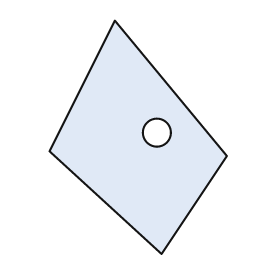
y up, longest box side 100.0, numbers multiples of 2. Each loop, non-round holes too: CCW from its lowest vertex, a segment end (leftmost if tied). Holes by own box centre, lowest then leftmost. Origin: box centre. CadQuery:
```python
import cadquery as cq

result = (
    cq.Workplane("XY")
    .moveTo(10.0, -50.0)
    .lineTo(38.0, -8.0)
    .lineTo(-10.0, 50.0)
    .lineTo(-38.0, -6.0)
    .close()
    .moveTo(8.0, 2.0)
    .circle(6.0)
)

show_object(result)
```